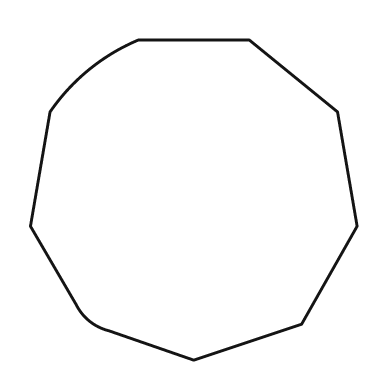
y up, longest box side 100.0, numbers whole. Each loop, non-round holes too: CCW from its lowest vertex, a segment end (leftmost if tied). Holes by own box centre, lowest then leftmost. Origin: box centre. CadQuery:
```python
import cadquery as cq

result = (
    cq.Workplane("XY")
    .moveTo(0.0, -49.0)
    .lineTo(33.0, -38.0)
    .lineTo(50.0, -8.0)
    .lineTo(44.0, 27.0)
    .lineTo(17.0, 49.0)
    .lineTo(-17.0, 49.0)
    .threePointArc((-32.0, 40.0), (-44.0, 27.0))
    .lineTo(-50.0, -8.0)
    .lineTo(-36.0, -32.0)
    .threePointArc((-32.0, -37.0), (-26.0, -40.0))
    .close()
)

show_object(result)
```